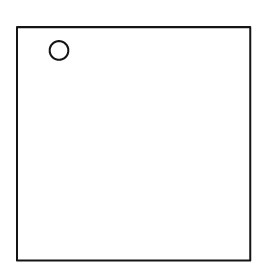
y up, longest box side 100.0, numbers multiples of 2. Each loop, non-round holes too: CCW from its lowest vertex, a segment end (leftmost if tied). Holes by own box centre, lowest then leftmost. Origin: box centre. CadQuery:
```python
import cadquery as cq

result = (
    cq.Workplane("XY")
    .moveTo(-50.0, -50.0)
    .lineTo(50.0, -50.0)
    .lineTo(50.0, 50.0)
    .lineTo(-50.0, 50.0)
    .close()
    .moveTo(-32.0, 40.0)
    .circle(4.0)
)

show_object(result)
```